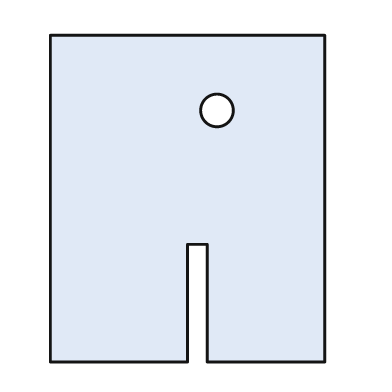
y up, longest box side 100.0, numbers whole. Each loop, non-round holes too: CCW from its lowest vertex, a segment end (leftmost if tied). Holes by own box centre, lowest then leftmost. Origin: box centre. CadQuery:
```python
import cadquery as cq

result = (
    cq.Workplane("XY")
    .moveTo(-42.0, -50.0)
    .lineTo(0.0, -50.0)
    .lineTo(0.0, -14.0)
    .lineTo(6.0, -14.0)
    .lineTo(6.0, -50.0)
    .lineTo(42.0, -50.0)
    .lineTo(42.0, 50.0)
    .lineTo(-42.0, 50.0)
    .close()
    .moveTo(9.0, 27.0)
    .circle(5.0)
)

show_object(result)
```